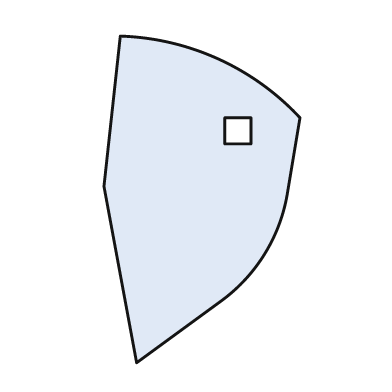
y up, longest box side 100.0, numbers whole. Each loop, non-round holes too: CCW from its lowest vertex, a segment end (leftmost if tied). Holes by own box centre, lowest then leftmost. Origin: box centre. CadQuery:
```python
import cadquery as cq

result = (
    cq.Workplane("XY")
    .moveTo(-20.0, -50.0)
    .lineTo(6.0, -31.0)
    .threePointArc((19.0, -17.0), (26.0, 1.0))
    .lineTo(30.0, 25.0)
    .threePointArc((5.0, 43.0), (-25.0, 50.0))
    .lineTo(-30.0, 4.0)
    .close()
    .moveTo(7.0, 17.0)
    .lineTo(15.0, 17.0)
    .lineTo(15.0, 25.0)
    .lineTo(7.0, 25.0)
    .close()
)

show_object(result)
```